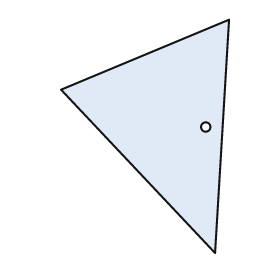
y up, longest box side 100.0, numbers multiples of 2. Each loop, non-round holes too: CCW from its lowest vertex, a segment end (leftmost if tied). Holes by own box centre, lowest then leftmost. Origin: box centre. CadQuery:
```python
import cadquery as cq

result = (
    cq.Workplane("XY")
    .moveTo(30.0, -50.0)
    .lineTo(36.0, 50.0)
    .lineTo(-36.0, 20.0)
    .close()
    .moveTo(26.0, 4.0)
    .circle(2.0)
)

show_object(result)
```